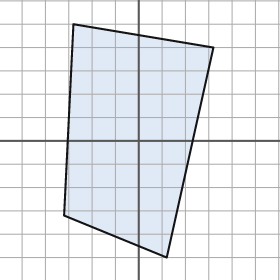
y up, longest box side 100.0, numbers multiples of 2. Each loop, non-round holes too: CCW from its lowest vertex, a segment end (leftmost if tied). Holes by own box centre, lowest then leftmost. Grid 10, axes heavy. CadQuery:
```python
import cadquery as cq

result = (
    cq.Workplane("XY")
    .moveTo(12.0, -50.0)
    .lineTo(32.0, 40.0)
    .lineTo(-28.0, 50.0)
    .lineTo(-32.0, -32.0)
    .close()
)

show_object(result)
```